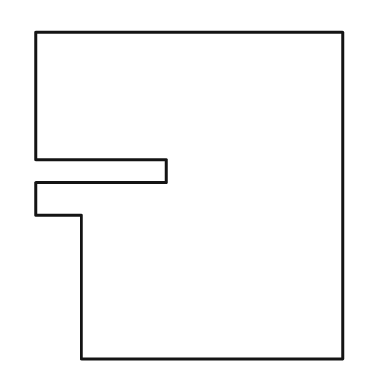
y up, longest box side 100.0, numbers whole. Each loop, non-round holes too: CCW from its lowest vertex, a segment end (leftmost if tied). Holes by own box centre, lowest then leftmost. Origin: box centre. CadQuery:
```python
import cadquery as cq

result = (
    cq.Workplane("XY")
    .moveTo(-33.0, -50.0)
    .lineTo(47.0, -50.0)
    .lineTo(47.0, 50.0)
    .lineTo(-47.0, 50.0)
    .lineTo(-47.0, 11.0)
    .lineTo(-7.0, 11.0)
    .lineTo(-7.0, 4.0)
    .lineTo(-47.0, 4.0)
    .lineTo(-47.0, -6.0)
    .lineTo(-33.0, -6.0)
    .close()
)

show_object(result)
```